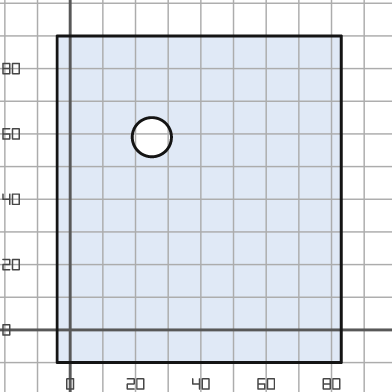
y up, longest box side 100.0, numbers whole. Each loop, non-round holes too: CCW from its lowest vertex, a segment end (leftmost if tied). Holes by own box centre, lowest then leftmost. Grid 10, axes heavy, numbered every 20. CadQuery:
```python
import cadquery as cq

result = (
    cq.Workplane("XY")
    .moveTo(-4.0, -10.0)
    .lineTo(83.0, -10.0)
    .lineTo(83.0, 90.0)
    .lineTo(-4.0, 90.0)
    .close()
    .moveTo(25.0, 59.0)
    .circle(6.0)
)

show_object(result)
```